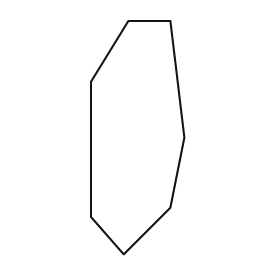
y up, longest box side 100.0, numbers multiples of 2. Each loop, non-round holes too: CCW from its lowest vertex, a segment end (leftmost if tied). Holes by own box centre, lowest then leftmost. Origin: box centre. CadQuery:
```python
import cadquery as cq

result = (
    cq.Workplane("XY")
    .moveTo(-6.0, -50.0)
    .lineTo(14.0, -30.0)
    .lineTo(20.0, 0.0)
    .lineTo(14.0, 50.0)
    .lineTo(-4.0, 50.0)
    .lineTo(-20.0, 24.0)
    .lineTo(-20.0, -34.0)
    .close()
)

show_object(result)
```